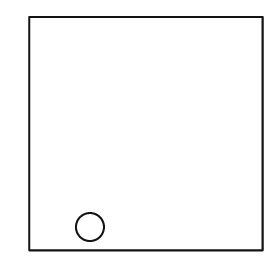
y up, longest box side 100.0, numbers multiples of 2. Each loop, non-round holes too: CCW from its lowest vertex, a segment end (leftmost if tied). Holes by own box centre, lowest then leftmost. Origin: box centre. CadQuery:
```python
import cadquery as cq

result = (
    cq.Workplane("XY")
    .moveTo(-50.0, -50.0)
    .lineTo(50.0, -50.0)
    .lineTo(50.0, 50.0)
    .lineTo(-50.0, 50.0)
    .close()
    .moveTo(-24.0, -40.0)
    .circle(6.0)
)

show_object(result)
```